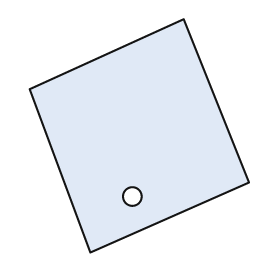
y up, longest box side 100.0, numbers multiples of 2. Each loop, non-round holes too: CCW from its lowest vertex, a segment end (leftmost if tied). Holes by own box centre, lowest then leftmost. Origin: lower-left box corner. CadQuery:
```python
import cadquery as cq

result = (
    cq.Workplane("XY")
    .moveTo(26.0, 0.0)
    .lineTo(94.0, 30.0)
    .lineTo(66.0, 100.0)
    .lineTo(0.0, 70.0)
    .close()
    .moveTo(44.0, 24.0)
    .circle(4.0)
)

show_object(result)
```